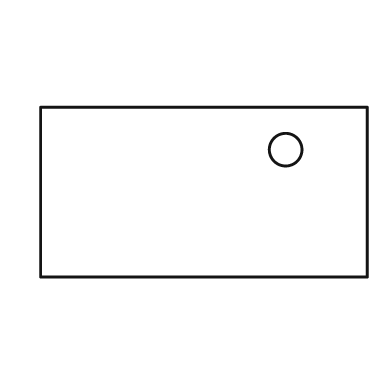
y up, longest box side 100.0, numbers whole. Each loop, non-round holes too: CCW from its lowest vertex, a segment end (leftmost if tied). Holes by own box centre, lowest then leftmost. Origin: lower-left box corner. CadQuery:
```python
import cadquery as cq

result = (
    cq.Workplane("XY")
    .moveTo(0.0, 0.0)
    .lineTo(100.0, 0.0)
    .lineTo(100.0, 52.0)
    .lineTo(0.0, 52.0)
    .close()
    .moveTo(75.0, 39.0)
    .circle(5.0)
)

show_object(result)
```